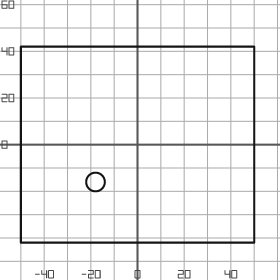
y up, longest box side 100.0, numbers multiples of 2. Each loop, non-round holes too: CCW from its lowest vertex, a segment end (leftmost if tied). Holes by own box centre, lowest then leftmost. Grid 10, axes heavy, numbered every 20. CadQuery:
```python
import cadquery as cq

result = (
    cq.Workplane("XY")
    .moveTo(-50.0, -42.0)
    .lineTo(50.0, -42.0)
    .lineTo(50.0, 42.0)
    .lineTo(-50.0, 42.0)
    .close()
    .moveTo(-18.0, -16.0)
    .circle(4.0)
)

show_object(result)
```